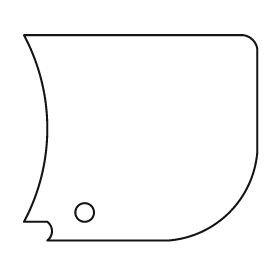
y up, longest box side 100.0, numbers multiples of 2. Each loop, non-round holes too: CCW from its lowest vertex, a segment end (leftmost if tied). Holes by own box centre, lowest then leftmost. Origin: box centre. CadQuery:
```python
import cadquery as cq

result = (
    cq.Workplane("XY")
    .moveTo(-40.0, -44.0)
    .lineTo(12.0, -44.0)
    .threePointArc((38.0, -32.0), (50.0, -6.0))
    .lineTo(50.0, 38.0)
    .threePointArc((48.0, 42.0), (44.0, 44.0))
    .lineTo(-50.0, 44.0)
    .threePointArc((-40.0, 4.0), (-50.0, -36.0))
    .lineTo(-40.0, -36.0)
    .threePointArc((-38.0, -40.0), (-40.0, -44.0))
    .close()
    .moveTo(-24.0, -32.0)
    .circle(4.0)
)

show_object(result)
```